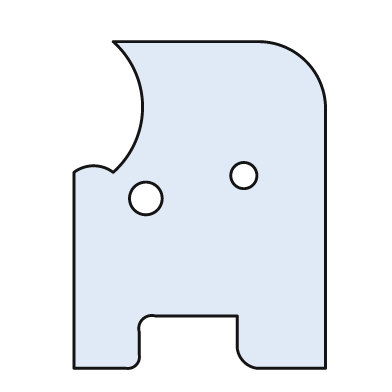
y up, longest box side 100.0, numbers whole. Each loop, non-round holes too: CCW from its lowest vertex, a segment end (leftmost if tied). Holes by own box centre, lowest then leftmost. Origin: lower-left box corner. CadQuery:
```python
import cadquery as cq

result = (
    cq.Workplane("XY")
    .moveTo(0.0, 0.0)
    .lineTo(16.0, 0.0)
    .threePointArc((19.0, 1.0), (20.0, 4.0))
    .lineTo(20.0, 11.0)
    .threePointArc((21.0, 15.0), (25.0, 16.0))
    .lineTo(50.0, 16.0)
    .lineTo(50.0, 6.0)
    .threePointArc((52.0, 2.0), (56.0, 0.0))
    .lineTo(77.0, 0.0)
    .lineTo(77.0, 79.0)
    .threePointArc((71.0, 94.0), (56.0, 100.0))
    .lineTo(12.0, 100.0)
    .threePointArc((21.0, 80.0), (12.0, 60.0))
    .threePointArc((6.0, 62.0), (0.0, 60.0))
    .close()
    .moveTo(22.0, 52.0)
    .circle(5.0)
    .moveTo(52.0, 59.0)
    .circle(4.0)
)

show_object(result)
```